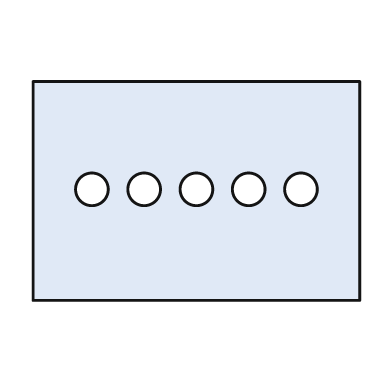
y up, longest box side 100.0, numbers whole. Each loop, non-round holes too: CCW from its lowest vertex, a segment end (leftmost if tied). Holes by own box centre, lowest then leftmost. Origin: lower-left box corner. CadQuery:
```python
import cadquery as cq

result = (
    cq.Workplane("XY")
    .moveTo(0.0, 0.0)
    .lineTo(100.0, 0.0)
    .lineTo(100.0, 67.0)
    .lineTo(0.0, 67.0)
    .close()
    .moveTo(18.0, 34.0)
    .circle(5.0)
    .moveTo(34.0, 34.0)
    .circle(5.0)
    .moveTo(50.0, 34.0)
    .circle(5.0)
    .moveTo(66.0, 34.0)
    .circle(5.0)
    .moveTo(82.0, 34.0)
    .circle(5.0)
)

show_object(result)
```